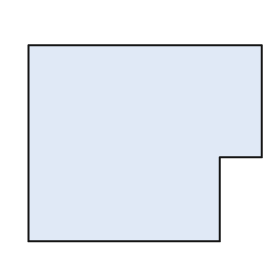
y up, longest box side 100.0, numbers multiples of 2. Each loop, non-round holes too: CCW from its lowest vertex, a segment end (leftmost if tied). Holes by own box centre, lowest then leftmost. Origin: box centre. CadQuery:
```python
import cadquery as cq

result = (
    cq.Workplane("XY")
    .moveTo(-50.0, -42.0)
    .lineTo(32.0, -42.0)
    .lineTo(32.0, -6.0)
    .lineTo(50.0, -6.0)
    .lineTo(50.0, 42.0)
    .lineTo(-50.0, 42.0)
    .close()
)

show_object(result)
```